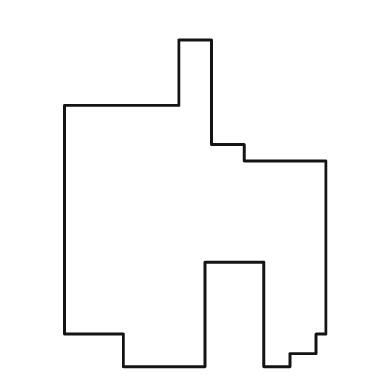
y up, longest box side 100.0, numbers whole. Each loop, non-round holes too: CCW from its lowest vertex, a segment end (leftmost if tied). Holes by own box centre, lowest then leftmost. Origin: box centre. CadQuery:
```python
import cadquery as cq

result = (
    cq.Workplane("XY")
    .moveTo(-22.0, -50.0)
    .lineTo(3.0, -50.0)
    .lineTo(3.0, -18.0)
    .lineTo(21.0, -18.0)
    .lineTo(21.0, -50.0)
    .lineTo(29.0, -50.0)
    .lineTo(29.0, -46.0)
    .lineTo(37.0, -46.0)
    .lineTo(37.0, -40.0)
    .lineTo(40.0, -40.0)
    .lineTo(40.0, 13.0)
    .lineTo(15.0, 13.0)
    .lineTo(15.0, 18.0)
    .lineTo(5.0, 18.0)
    .lineTo(5.0, 50.0)
    .lineTo(-5.0, 50.0)
    .lineTo(-5.0, 30.0)
    .lineTo(-40.0, 30.0)
    .lineTo(-40.0, -40.0)
    .lineTo(-22.0, -40.0)
    .close()
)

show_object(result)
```